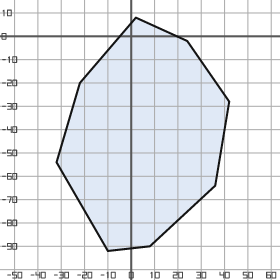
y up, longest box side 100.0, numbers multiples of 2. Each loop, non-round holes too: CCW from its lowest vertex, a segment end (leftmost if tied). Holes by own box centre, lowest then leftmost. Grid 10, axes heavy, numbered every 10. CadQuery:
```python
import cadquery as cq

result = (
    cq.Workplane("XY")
    .moveTo(-10.0, -92.0)
    .lineTo(8.0, -90.0)
    .lineTo(36.0, -64.0)
    .lineTo(42.0, -28.0)
    .lineTo(24.0, -2.0)
    .lineTo(2.0, 8.0)
    .lineTo(-22.0, -20.0)
    .lineTo(-32.0, -54.0)
    .close()
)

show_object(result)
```